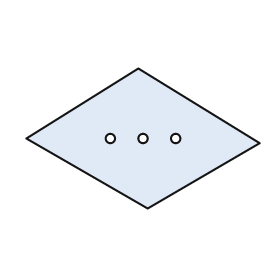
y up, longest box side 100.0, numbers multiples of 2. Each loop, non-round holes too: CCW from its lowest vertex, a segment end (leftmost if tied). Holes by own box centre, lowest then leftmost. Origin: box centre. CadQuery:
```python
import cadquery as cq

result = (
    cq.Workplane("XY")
    .moveTo(2.0, -30.0)
    .lineTo(50.0, -2.0)
    .lineTo(-2.0, 30.0)
    .lineTo(-50.0, 0.0)
    .close()
    .moveTo(-14.0, 0.0)
    .circle(2.0)
    .moveTo(0.0, 0.0)
    .circle(2.0)
    .moveTo(14.0, 0.0)
    .circle(2.0)
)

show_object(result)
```